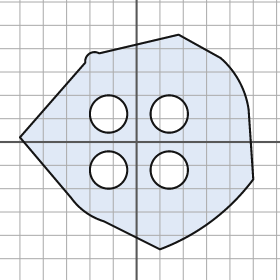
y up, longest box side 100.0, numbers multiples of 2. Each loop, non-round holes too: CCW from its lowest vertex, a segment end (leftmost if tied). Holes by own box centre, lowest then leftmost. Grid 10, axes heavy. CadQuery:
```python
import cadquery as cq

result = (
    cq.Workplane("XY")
    .moveTo(10.0, -46.0)
    .threePointArc((32.0, -34.0), (50.0, -16.0))
    .lineTo(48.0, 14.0)
    .threePointArc((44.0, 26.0), (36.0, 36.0))
    .lineTo(18.0, 46.0)
    .lineTo(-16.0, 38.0)
    .threePointArc((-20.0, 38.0), (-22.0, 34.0))
    .lineTo(-50.0, 2.0)
    .lineTo(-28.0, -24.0)
    .threePointArc((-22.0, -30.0), (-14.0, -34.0))
    .close()
    .moveTo(-12.0, -12.0)
    .circle(8.0)
    .moveTo(14.0, -12.0)
    .circle(8.0)
    .moveTo(-12.0, 12.0)
    .circle(8.0)
    .moveTo(14.0, 12.0)
    .circle(8.0)
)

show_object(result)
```